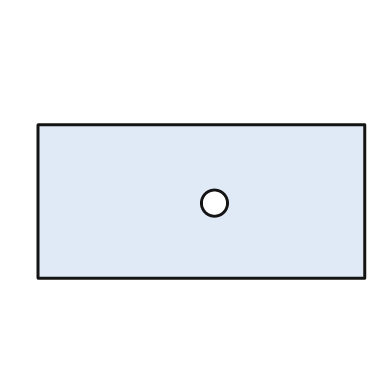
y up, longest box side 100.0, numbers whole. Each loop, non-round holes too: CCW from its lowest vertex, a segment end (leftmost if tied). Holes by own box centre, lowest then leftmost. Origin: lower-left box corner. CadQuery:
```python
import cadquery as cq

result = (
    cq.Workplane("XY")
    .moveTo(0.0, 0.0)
    .lineTo(100.0, 0.0)
    .lineTo(100.0, 47.0)
    .lineTo(0.0, 47.0)
    .close()
    .moveTo(54.0, 23.0)
    .circle(4.0)
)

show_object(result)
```